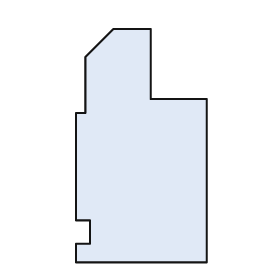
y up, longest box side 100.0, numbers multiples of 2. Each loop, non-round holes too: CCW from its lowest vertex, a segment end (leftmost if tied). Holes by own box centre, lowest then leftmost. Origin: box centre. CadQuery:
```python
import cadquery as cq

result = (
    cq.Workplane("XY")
    .moveTo(-28.0, -50.0)
    .lineTo(28.0, -50.0)
    .lineTo(28.0, 20.0)
    .lineTo(4.0, 20.0)
    .lineTo(4.0, 50.0)
    .lineTo(-12.0, 50.0)
    .lineTo(-24.0, 38.0)
    .lineTo(-24.0, 14.0)
    .lineTo(-28.0, 14.0)
    .lineTo(-28.0, -32.0)
    .lineTo(-22.0, -32.0)
    .lineTo(-22.0, -42.0)
    .lineTo(-28.0, -42.0)
    .close()
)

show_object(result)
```